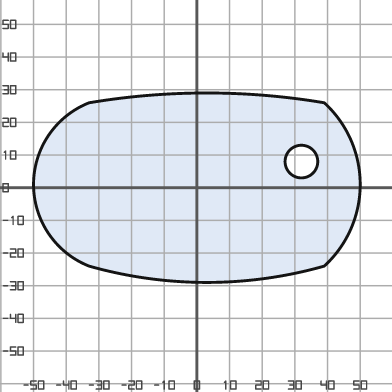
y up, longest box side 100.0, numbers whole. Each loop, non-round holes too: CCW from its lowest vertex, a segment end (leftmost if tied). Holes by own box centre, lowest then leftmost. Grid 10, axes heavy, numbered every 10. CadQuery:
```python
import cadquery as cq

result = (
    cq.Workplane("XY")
    .moveTo(-33.0, -24.0)
    .threePointArc((3.0, -29.0), (39.0, -24.0))
    .threePointArc((50.0, 1.0), (39.0, 26.0))
    .threePointArc((3.0, 29.0), (-33.0, 26.0))
    .threePointArc((-50.0, 1.0), (-33.0, -24.0))
    .close()
    .moveTo(32.0, 8.0)
    .circle(5.0)
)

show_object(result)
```